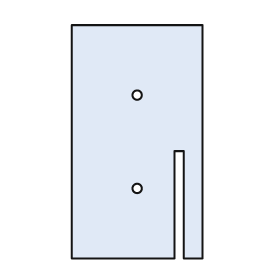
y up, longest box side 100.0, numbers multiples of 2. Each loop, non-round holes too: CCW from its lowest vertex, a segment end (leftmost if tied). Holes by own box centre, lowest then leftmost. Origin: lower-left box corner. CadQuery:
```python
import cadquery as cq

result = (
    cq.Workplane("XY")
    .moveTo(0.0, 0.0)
    .lineTo(44.0, 0.0)
    .lineTo(44.0, 46.0)
    .lineTo(48.0, 46.0)
    .lineTo(48.0, 0.0)
    .lineTo(56.0, 0.0)
    .lineTo(56.0, 100.0)
    .lineTo(0.0, 100.0)
    .close()
    .moveTo(28.0, 30.0)
    .circle(2.0)
    .moveTo(28.0, 70.0)
    .circle(2.0)
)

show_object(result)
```